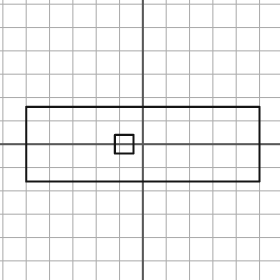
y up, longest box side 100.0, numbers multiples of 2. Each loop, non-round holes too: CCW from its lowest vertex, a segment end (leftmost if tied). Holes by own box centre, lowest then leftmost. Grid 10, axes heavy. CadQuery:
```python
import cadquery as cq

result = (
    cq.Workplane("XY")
    .moveTo(-50.0, -16.0)
    .lineTo(50.0, -16.0)
    .lineTo(50.0, 16.0)
    .lineTo(-50.0, 16.0)
    .close()
    .moveTo(-12.0, -4.0)
    .lineTo(-4.0, -4.0)
    .lineTo(-4.0, 4.0)
    .lineTo(-12.0, 4.0)
    .close()
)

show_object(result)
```